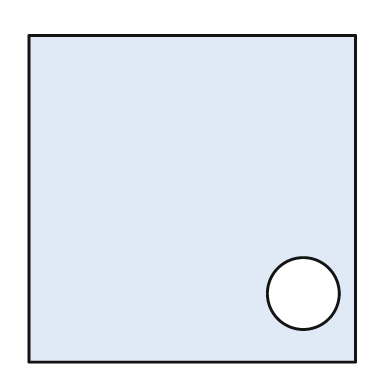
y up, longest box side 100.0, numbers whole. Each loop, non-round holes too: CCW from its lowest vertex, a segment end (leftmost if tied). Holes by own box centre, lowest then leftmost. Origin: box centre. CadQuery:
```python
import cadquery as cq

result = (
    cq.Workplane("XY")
    .moveTo(-50.0, -50.0)
    .lineTo(50.0, -50.0)
    .lineTo(50.0, 50.0)
    .lineTo(-50.0, 50.0)
    .close()
    .moveTo(34.0, -29.0)
    .circle(11.0)
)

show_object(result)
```